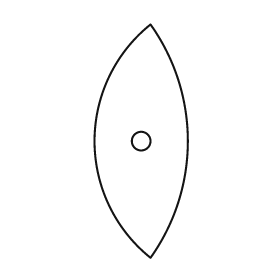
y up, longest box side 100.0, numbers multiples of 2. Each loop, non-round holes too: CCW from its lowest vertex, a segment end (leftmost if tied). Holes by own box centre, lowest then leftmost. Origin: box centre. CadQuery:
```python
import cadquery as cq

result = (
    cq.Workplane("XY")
    .moveTo(4.0, -50.0)
    .threePointArc((20.0, 0.0), (4.0, 50.0))
    .threePointArc((-20.0, 0.0), (4.0, -50.0))
    .close()
    .moveTo(0.0, 0.0)
    .circle(4.0)
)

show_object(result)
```